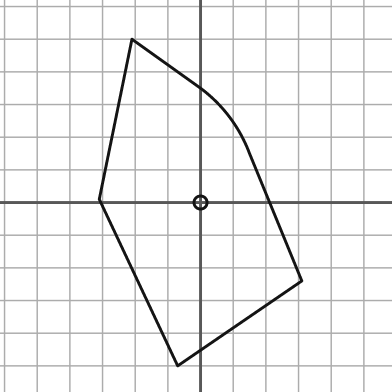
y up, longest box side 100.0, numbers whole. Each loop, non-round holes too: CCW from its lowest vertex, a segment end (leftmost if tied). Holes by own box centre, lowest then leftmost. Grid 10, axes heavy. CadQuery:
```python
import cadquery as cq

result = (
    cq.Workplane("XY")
    .moveTo(-7.0, -50.0)
    .lineTo(31.0, -24.0)
    .lineTo(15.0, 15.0)
    .threePointArc((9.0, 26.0), (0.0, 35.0))
    .lineTo(-21.0, 50.0)
    .lineTo(-31.0, 1.0)
    .close()
    .moveTo(0.0, 0.0)
    .circle(2.0)
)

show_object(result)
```